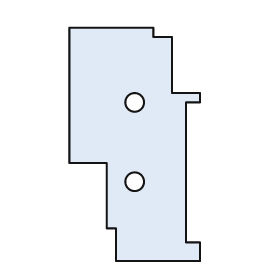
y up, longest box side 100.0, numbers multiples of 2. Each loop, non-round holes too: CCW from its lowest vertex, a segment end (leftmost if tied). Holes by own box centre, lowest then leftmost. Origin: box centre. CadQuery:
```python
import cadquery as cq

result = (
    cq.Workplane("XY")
    .moveTo(-8.0, -50.0)
    .lineTo(28.0, -50.0)
    .lineTo(28.0, -42.0)
    .lineTo(22.0, -42.0)
    .lineTo(22.0, 18.0)
    .lineTo(28.0, 18.0)
    .lineTo(28.0, 22.0)
    .lineTo(16.0, 22.0)
    .lineTo(16.0, 46.0)
    .lineTo(8.0, 46.0)
    .lineTo(8.0, 50.0)
    .lineTo(-28.0, 50.0)
    .lineTo(-28.0, -8.0)
    .lineTo(-12.0, -8.0)
    .lineTo(-12.0, -36.0)
    .lineTo(-8.0, -36.0)
    .close()
    .moveTo(0.0, -16.0)
    .circle(4.0)
    .moveTo(0.0, 18.0)
    .circle(4.0)
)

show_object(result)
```